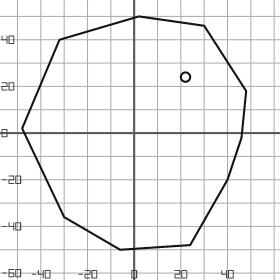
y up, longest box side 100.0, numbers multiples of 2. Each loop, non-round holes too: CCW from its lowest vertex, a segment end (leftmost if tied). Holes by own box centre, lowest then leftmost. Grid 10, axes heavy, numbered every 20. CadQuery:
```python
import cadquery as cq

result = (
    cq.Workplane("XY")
    .moveTo(-6.0, -50.0)
    .lineTo(24.0, -48.0)
    .lineTo(40.0, -20.0)
    .lineTo(46.0, -2.0)
    .lineTo(48.0, 18.0)
    .lineTo(30.0, 46.0)
    .lineTo(2.0, 50.0)
    .lineTo(-32.0, 40.0)
    .lineTo(-48.0, 2.0)
    .lineTo(-30.0, -36.0)
    .close()
    .moveTo(22.0, 24.0)
    .circle(2.0)
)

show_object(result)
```